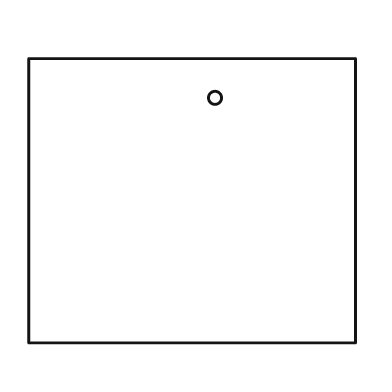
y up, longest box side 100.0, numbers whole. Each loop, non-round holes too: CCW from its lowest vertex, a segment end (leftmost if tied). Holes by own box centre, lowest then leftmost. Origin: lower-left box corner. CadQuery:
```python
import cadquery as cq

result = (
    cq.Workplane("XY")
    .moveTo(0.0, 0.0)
    .lineTo(100.0, 0.0)
    .lineTo(100.0, 87.0)
    .lineTo(0.0, 87.0)
    .close()
    .moveTo(57.0, 75.0)
    .circle(2.0)
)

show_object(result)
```